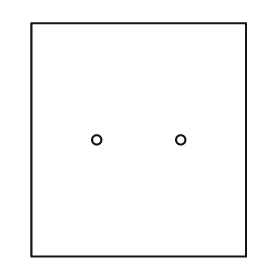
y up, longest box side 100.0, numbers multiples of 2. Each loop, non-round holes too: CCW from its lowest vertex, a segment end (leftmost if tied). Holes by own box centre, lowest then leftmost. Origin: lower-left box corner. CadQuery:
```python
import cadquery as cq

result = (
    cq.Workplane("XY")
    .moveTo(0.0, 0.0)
    .lineTo(92.0, 0.0)
    .lineTo(92.0, 100.0)
    .lineTo(0.0, 100.0)
    .close()
    .moveTo(28.0, 50.0)
    .circle(2.0)
    .moveTo(64.0, 50.0)
    .circle(2.0)
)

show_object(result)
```